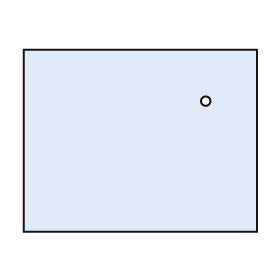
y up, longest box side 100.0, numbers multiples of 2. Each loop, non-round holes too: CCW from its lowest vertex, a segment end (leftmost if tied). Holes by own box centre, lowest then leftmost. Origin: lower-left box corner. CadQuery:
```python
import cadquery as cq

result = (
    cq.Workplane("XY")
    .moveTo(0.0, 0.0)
    .lineTo(100.0, 0.0)
    .lineTo(100.0, 78.0)
    .lineTo(0.0, 78.0)
    .close()
    .moveTo(78.0, 56.0)
    .circle(2.0)
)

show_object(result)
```